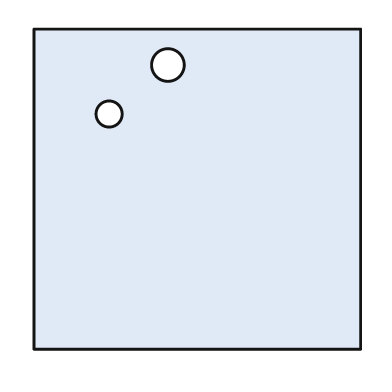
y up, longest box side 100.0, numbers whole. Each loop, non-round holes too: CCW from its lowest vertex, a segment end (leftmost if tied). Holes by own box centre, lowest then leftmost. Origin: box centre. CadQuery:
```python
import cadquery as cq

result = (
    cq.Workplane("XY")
    .moveTo(-50.0, -49.0)
    .lineTo(50.0, -49.0)
    .lineTo(50.0, 49.0)
    .lineTo(-50.0, 49.0)
    .close()
    .moveTo(-27.0, 23.0)
    .circle(4.0)
    .moveTo(-9.0, 38.0)
    .circle(5.0)
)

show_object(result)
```